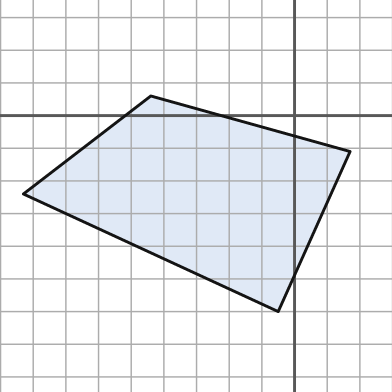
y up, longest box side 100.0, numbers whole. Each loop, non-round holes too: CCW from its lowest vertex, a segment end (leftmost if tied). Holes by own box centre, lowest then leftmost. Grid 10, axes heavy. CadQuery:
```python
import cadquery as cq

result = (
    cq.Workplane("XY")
    .moveTo(-5.0, -60.0)
    .lineTo(17.0, -11.0)
    .lineTo(-44.0, 6.0)
    .lineTo(-83.0, -24.0)
    .close()
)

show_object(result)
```